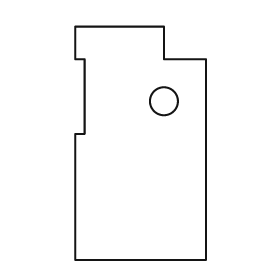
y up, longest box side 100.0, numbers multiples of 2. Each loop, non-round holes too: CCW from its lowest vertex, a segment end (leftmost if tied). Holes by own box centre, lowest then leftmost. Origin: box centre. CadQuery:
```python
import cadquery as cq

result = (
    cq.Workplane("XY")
    .moveTo(-28.0, -50.0)
    .lineTo(28.0, -50.0)
    .lineTo(28.0, 36.0)
    .lineTo(10.0, 36.0)
    .lineTo(10.0, 50.0)
    .lineTo(-28.0, 50.0)
    .lineTo(-28.0, 36.0)
    .lineTo(-24.0, 36.0)
    .lineTo(-24.0, 4.0)
    .lineTo(-28.0, 4.0)
    .close()
    .moveTo(10.0, 18.0)
    .circle(6.0)
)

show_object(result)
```